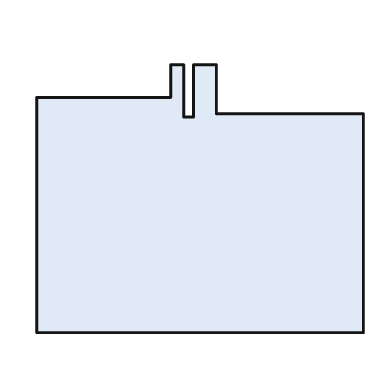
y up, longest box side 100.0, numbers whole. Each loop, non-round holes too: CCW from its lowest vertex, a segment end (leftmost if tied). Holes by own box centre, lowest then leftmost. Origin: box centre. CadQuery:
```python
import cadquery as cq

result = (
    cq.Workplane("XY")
    .moveTo(-50.0, -41.0)
    .lineTo(50.0, -41.0)
    .lineTo(50.0, 26.0)
    .lineTo(5.0, 26.0)
    .lineTo(5.0, 41.0)
    .lineTo(-2.0, 41.0)
    .lineTo(-2.0, 25.0)
    .lineTo(-5.0, 25.0)
    .lineTo(-5.0, 41.0)
    .lineTo(-9.0, 41.0)
    .lineTo(-9.0, 31.0)
    .lineTo(-50.0, 31.0)
    .close()
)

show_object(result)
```